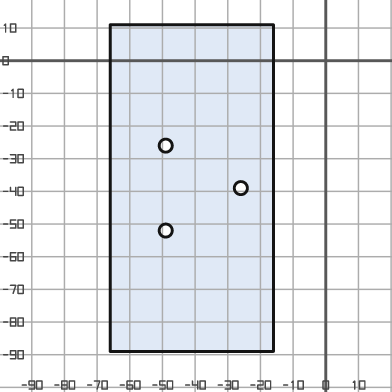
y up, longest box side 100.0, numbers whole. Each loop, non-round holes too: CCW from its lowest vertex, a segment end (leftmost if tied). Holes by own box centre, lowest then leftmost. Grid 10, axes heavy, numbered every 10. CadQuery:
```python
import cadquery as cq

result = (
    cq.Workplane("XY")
    .moveTo(-66.0, -89.0)
    .lineTo(-16.0, -89.0)
    .lineTo(-16.0, 11.0)
    .lineTo(-66.0, 11.0)
    .close()
    .moveTo(-49.0, -52.0)
    .circle(2.0)
    .moveTo(-26.0, -39.0)
    .circle(2.0)
    .moveTo(-49.0, -26.0)
    .circle(2.0)
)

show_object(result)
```